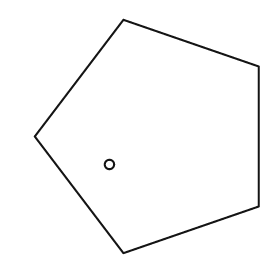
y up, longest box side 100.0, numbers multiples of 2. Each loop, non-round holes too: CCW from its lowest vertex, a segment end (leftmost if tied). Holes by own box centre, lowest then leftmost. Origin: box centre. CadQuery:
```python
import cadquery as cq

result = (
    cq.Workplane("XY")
    .moveTo(-10.0, -50.0)
    .lineTo(48.0, -30.0)
    .lineTo(48.0, 30.0)
    .lineTo(-10.0, 50.0)
    .lineTo(-48.0, 0.0)
    .close()
    .moveTo(-16.0, -12.0)
    .circle(2.0)
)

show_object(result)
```